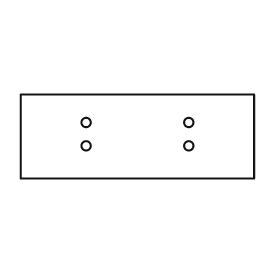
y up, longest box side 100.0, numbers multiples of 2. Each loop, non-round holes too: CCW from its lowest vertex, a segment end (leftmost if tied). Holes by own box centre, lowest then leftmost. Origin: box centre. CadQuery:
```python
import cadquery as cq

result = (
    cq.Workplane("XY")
    .moveTo(-50.0, -18.0)
    .lineTo(50.0, -18.0)
    .lineTo(50.0, 18.0)
    .lineTo(-50.0, 18.0)
    .close()
    .moveTo(-22.0, -4.0)
    .circle(2.0)
    .moveTo(22.0, -4.0)
    .circle(2.0)
    .moveTo(-22.0, 6.0)
    .circle(2.0)
    .moveTo(22.0, 6.0)
    .circle(2.0)
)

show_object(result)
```